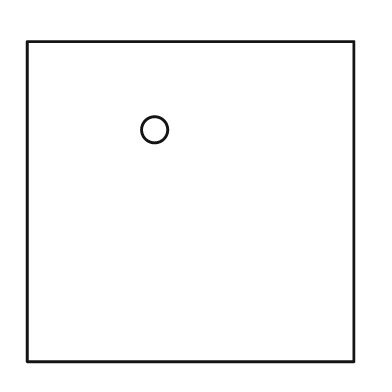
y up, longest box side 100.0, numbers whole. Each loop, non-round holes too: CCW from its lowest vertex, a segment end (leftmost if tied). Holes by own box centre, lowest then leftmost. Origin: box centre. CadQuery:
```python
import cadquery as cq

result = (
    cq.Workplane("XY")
    .moveTo(-50.0, -49.0)
    .lineTo(50.0, -49.0)
    .lineTo(50.0, 49.0)
    .lineTo(-50.0, 49.0)
    .close()
    .moveTo(-11.0, 22.0)
    .circle(4.0)
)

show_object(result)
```